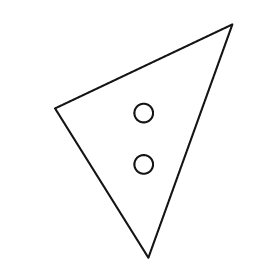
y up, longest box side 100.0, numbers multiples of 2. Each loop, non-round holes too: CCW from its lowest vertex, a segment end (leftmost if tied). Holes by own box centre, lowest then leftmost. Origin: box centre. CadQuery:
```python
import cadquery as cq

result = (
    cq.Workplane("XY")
    .moveTo(2.0, -50.0)
    .lineTo(38.0, 50.0)
    .lineTo(-38.0, 14.0)
    .close()
    .moveTo(0.0, -10.0)
    .circle(4.0)
    .moveTo(0.0, 12.0)
    .circle(4.0)
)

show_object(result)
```